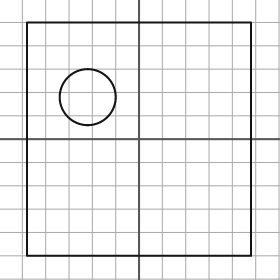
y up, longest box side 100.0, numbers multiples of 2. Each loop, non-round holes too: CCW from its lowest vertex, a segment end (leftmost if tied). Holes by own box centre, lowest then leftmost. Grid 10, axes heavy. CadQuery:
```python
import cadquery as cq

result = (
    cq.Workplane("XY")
    .moveTo(-48.0, -50.0)
    .lineTo(48.0, -50.0)
    .lineTo(48.0, 50.0)
    .lineTo(-48.0, 50.0)
    .close()
    .moveTo(-22.0, 18.0)
    .circle(12.0)
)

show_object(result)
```